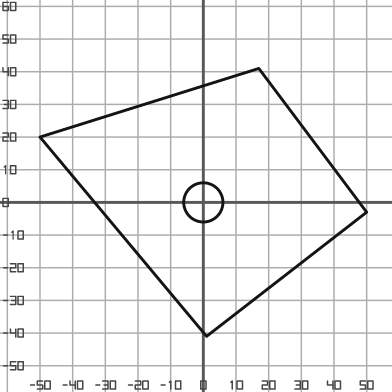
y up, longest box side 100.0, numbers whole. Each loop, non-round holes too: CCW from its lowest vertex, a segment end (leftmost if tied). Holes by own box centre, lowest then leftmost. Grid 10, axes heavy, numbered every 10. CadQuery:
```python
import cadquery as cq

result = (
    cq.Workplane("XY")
    .moveTo(1.0, -41.0)
    .lineTo(50.0, -3.0)
    .lineTo(17.0, 41.0)
    .lineTo(-50.0, 20.0)
    .close()
    .moveTo(0.0, 0.0)
    .circle(6.0)
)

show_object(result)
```